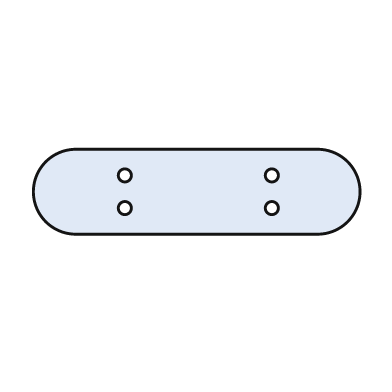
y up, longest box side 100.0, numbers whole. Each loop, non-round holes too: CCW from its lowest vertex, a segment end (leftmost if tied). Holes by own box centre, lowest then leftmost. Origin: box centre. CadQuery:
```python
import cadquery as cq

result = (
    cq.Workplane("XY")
    .moveTo(-37.0, -13.0)
    .lineTo(37.0, -13.0)
    .threePointArc((50.0, 0.0), (37.0, 13.0))
    .lineTo(-37.0, 13.0)
    .threePointArc((-50.0, 0.0), (-37.0, -13.0))
    .close()
    .moveTo(-22.0, -5.0)
    .circle(2.0)
    .moveTo(23.0, -5.0)
    .circle(2.0)
    .moveTo(-22.0, 5.0)
    .circle(2.0)
    .moveTo(23.0, 5.0)
    .circle(2.0)
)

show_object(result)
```